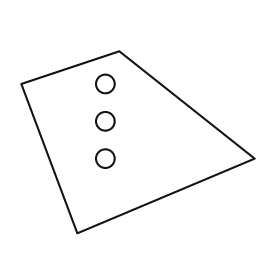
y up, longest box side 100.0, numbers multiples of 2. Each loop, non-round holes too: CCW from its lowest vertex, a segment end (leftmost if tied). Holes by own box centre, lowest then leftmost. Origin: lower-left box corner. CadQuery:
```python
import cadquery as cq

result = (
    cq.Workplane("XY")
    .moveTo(24.0, 0.0)
    .lineTo(100.0, 32.0)
    .lineTo(42.0, 78.0)
    .lineTo(0.0, 64.0)
    .close()
    .moveTo(36.0, 32.0)
    .circle(4.0)
    .moveTo(36.0, 48.0)
    .circle(4.0)
    .moveTo(36.0, 64.0)
    .circle(4.0)
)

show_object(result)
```